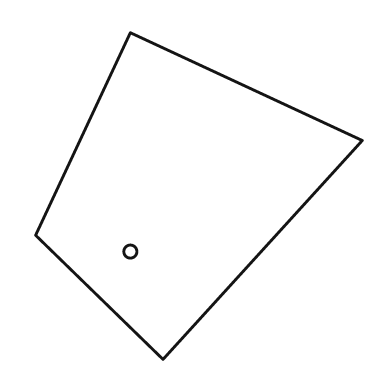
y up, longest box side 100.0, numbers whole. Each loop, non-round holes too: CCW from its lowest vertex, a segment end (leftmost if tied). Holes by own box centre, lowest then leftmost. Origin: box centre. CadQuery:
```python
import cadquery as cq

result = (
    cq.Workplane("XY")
    .moveTo(-11.0, -50.0)
    .lineTo(50.0, 17.0)
    .lineTo(-21.0, 50.0)
    .lineTo(-50.0, -12.0)
    .close()
    .moveTo(-21.0, -17.0)
    .circle(2.0)
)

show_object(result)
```